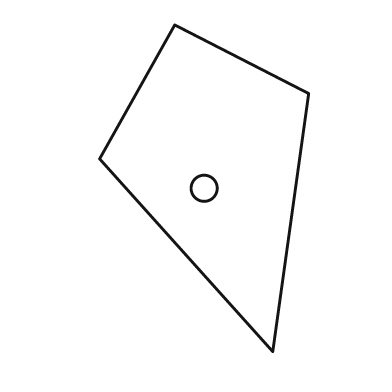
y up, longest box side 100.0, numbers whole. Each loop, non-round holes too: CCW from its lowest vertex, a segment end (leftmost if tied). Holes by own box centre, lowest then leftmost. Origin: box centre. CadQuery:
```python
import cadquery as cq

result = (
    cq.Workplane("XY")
    .moveTo(21.0, -50.0)
    .lineTo(32.0, 29.0)
    .lineTo(-9.0, 50.0)
    .lineTo(-32.0, 9.0)
    .close()
    .moveTo(0.0, 0.0)
    .circle(4.0)
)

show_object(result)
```